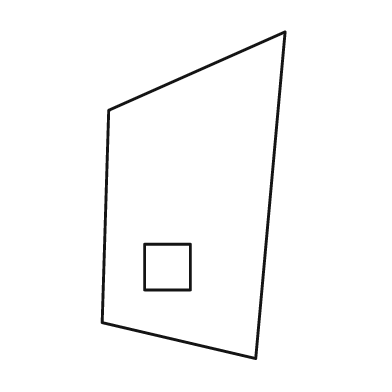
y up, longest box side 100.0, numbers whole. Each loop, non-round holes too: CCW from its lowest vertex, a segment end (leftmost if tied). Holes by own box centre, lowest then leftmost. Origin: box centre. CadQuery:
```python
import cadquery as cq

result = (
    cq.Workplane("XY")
    .moveTo(19.0, -50.0)
    .lineTo(28.0, 50.0)
    .lineTo(-26.0, 26.0)
    .lineTo(-28.0, -39.0)
    .close()
    .moveTo(-15.0, -29.0)
    .lineTo(-1.0, -29.0)
    .lineTo(-1.0, -15.0)
    .lineTo(-15.0, -15.0)
    .close()
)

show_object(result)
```